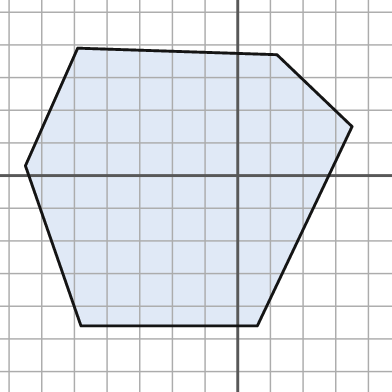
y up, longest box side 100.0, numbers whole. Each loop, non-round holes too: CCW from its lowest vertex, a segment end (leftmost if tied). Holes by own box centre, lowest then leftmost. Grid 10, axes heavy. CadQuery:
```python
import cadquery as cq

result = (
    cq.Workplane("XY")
    .moveTo(-48.0, -46.0)
    .lineTo(6.0, -46.0)
    .lineTo(35.0, 15.0)
    .lineTo(12.0, 37.0)
    .lineTo(-49.0, 39.0)
    .lineTo(-65.0, 3.0)
    .close()
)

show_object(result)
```